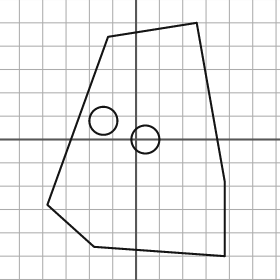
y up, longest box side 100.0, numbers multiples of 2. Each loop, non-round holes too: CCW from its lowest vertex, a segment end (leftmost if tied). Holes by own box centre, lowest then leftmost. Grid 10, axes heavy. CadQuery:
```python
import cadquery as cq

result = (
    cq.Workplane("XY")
    .moveTo(38.0, -50.0)
    .lineTo(38.0, -18.0)
    .lineTo(26.0, 50.0)
    .lineTo(-12.0, 44.0)
    .lineTo(-38.0, -28.0)
    .lineTo(-18.0, -46.0)
    .close()
    .moveTo(4.0, 0.0)
    .circle(6.0)
    .moveTo(-14.0, 8.0)
    .circle(6.0)
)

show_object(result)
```